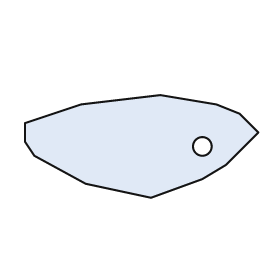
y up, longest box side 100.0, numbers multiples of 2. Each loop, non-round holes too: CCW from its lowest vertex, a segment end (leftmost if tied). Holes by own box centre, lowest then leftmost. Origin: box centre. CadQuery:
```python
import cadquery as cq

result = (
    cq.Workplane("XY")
    .moveTo(4.0, -22.0)
    .lineTo(26.0, -14.0)
    .lineTo(36.0, -8.0)
    .lineTo(50.0, 6.0)
    .lineTo(42.0, 14.0)
    .lineTo(32.0, 18.0)
    .lineTo(8.0, 22.0)
    .lineTo(-26.0, 18.0)
    .lineTo(-50.0, 10.0)
    .lineTo(-50.0, 2.0)
    .lineTo(-46.0, -4.0)
    .lineTo(-24.0, -16.0)
    .close()
    .moveTo(26.0, 0.0)
    .circle(4.0)
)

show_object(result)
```